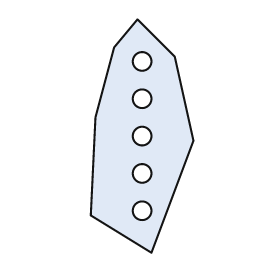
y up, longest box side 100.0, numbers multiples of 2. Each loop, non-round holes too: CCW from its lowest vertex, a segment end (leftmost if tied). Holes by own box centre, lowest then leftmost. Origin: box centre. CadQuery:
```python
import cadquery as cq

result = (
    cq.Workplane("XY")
    .moveTo(4.0, -50.0)
    .lineTo(22.0, -2.0)
    .lineTo(14.0, 34.0)
    .lineTo(-2.0, 50.0)
    .lineTo(-12.0, 38.0)
    .lineTo(-20.0, 8.0)
    .lineTo(-22.0, -34.0)
    .close()
    .moveTo(0.0, -32.0)
    .circle(4.0)
    .moveTo(0.0, -16.0)
    .circle(4.0)
    .moveTo(0.0, 0.0)
    .circle(4.0)
    .moveTo(0.0, 16.0)
    .circle(4.0)
    .moveTo(0.0, 32.0)
    .circle(4.0)
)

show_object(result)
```